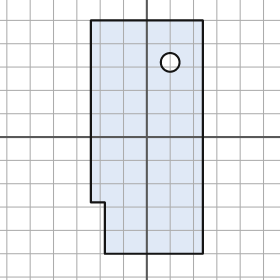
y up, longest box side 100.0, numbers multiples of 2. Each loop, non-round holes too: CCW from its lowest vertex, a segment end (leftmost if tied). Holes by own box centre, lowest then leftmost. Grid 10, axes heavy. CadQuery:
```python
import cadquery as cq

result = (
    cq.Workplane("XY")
    .moveTo(-18.0, -50.0)
    .lineTo(24.0, -50.0)
    .lineTo(24.0, 50.0)
    .lineTo(-24.0, 50.0)
    .lineTo(-24.0, -28.0)
    .lineTo(-18.0, -28.0)
    .close()
    .moveTo(10.0, 32.0)
    .circle(4.0)
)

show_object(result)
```